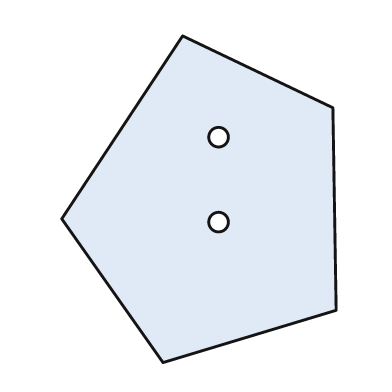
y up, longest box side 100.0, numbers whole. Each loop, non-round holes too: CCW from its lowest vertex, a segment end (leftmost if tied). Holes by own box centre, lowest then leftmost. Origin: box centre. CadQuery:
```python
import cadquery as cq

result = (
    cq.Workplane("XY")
    .moveTo(-11.0, -50.0)
    .lineTo(42.0, -34.0)
    .lineTo(41.0, 28.0)
    .lineTo(-5.0, 50.0)
    .lineTo(-42.0, -6.0)
    .close()
    .moveTo(6.0, -7.0)
    .circle(3.0)
    .moveTo(6.0, 19.0)
    .circle(3.0)
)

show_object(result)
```